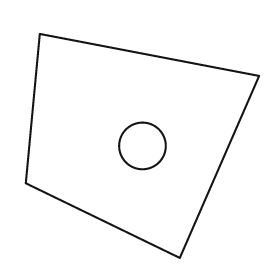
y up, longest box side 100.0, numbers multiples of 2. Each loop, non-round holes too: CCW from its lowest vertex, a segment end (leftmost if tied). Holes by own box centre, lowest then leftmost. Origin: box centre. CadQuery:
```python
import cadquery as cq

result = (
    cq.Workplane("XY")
    .moveTo(16.0, -48.0)
    .lineTo(50.0, 30.0)
    .lineTo(-44.0, 48.0)
    .lineTo(-50.0, -16.0)
    .close()
    .moveTo(0.0, 0.0)
    .circle(10.0)
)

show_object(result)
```